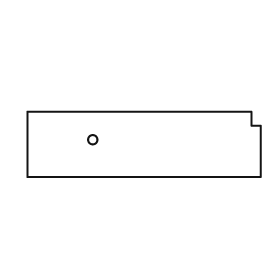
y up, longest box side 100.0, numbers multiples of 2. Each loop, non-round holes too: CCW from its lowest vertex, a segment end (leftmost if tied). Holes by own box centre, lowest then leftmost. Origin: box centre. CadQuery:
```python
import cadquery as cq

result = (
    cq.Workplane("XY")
    .moveTo(-50.0, -14.0)
    .lineTo(50.0, -14.0)
    .lineTo(50.0, 8.0)
    .lineTo(46.0, 8.0)
    .lineTo(46.0, 14.0)
    .lineTo(-50.0, 14.0)
    .close()
    .moveTo(-22.0, 2.0)
    .circle(2.0)
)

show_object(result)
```